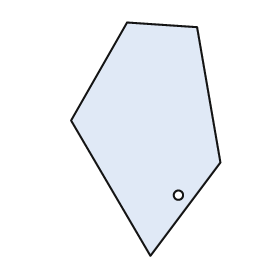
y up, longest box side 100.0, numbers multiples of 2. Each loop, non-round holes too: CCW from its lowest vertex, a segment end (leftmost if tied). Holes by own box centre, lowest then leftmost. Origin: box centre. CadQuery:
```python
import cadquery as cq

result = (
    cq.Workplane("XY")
    .moveTo(2.0, -50.0)
    .lineTo(32.0, -10.0)
    .lineTo(22.0, 48.0)
    .lineTo(-8.0, 50.0)
    .lineTo(-32.0, 8.0)
    .close()
    .moveTo(14.0, -24.0)
    .circle(2.0)
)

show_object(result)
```